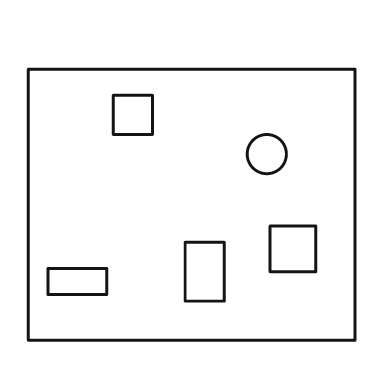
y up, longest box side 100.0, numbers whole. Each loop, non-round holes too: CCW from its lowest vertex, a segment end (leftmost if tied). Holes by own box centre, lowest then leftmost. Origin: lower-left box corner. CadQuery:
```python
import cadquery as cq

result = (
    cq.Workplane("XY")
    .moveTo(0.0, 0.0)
    .lineTo(100.0, 0.0)
    .lineTo(100.0, 83.0)
    .lineTo(0.0, 83.0)
    .close()
    .moveTo(6.0, 14.0)
    .lineTo(24.0, 14.0)
    .lineTo(24.0, 22.0)
    .lineTo(6.0, 22.0)
    .close()
    .moveTo(48.0, 12.0)
    .lineTo(60.0, 12.0)
    .lineTo(60.0, 30.0)
    .lineTo(48.0, 30.0)
    .close()
    .moveTo(74.0, 21.0)
    .lineTo(88.0, 21.0)
    .lineTo(88.0, 35.0)
    .lineTo(74.0, 35.0)
    .close()
    .moveTo(73.0, 57.0)
    .circle(6.0)
    .moveTo(26.0, 63.0)
    .lineTo(38.0, 63.0)
    .lineTo(38.0, 75.0)
    .lineTo(26.0, 75.0)
    .close()
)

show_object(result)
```